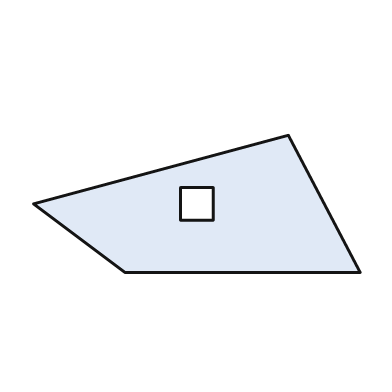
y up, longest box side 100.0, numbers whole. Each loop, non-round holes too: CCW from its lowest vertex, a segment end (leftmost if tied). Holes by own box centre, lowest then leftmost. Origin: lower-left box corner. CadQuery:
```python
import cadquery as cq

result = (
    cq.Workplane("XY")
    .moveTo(28.0, 0.0)
    .lineTo(100.0, 0.0)
    .lineTo(78.0, 42.0)
    .lineTo(0.0, 21.0)
    .close()
    .moveTo(45.0, 16.0)
    .lineTo(55.0, 16.0)
    .lineTo(55.0, 26.0)
    .lineTo(45.0, 26.0)
    .close()
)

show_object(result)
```